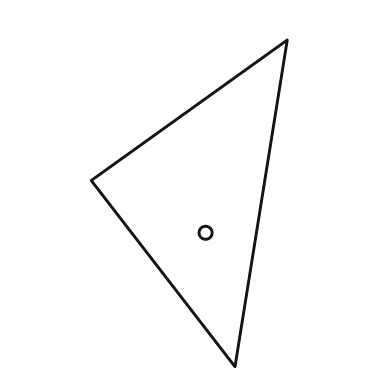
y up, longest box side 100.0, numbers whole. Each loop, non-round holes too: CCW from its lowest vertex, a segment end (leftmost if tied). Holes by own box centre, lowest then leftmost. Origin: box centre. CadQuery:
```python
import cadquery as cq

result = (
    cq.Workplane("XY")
    .moveTo(14.0, -50.0)
    .lineTo(30.0, 50.0)
    .lineTo(-30.0, 7.0)
    .close()
    .moveTo(5.0, -9.0)
    .circle(2.0)
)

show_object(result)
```